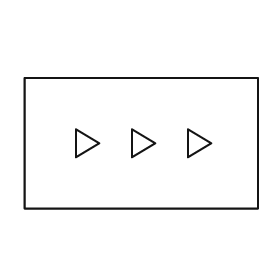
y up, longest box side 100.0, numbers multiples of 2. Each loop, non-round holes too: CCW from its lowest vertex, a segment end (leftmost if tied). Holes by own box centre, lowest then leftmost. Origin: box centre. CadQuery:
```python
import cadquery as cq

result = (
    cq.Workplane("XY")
    .moveTo(-50.0, -28.0)
    .lineTo(50.0, -28.0)
    .lineTo(50.0, 28.0)
    .lineTo(-50.0, 28.0)
    .close()
    .moveTo(-28.0, -6.0)
    .lineTo(-18.0, 0.0)
    .lineTo(-28.0, 6.0)
    .close()
    .moveTo(-4.0, -6.0)
    .lineTo(6.0, 0.0)
    .lineTo(-4.0, 6.0)
    .close()
    .moveTo(20.0, -6.0)
    .lineTo(30.0, 0.0)
    .lineTo(20.0, 6.0)
    .close()
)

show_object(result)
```